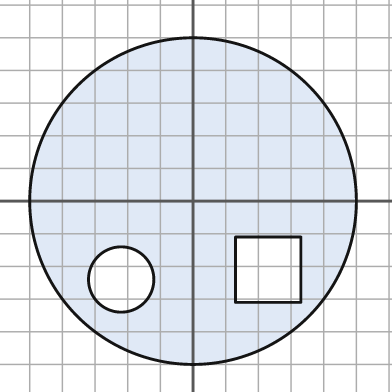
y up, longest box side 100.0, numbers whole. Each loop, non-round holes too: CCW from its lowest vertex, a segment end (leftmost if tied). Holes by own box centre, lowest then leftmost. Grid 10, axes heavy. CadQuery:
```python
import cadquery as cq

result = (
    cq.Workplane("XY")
    .moveTo(0.0, 0.0)
    .circle(50.0)
    .moveTo(-22.0, -24.0)
    .circle(10.0)
    .moveTo(13.0, -31.0)
    .lineTo(33.0, -31.0)
    .lineTo(33.0, -11.0)
    .lineTo(13.0, -11.0)
    .close()
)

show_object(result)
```